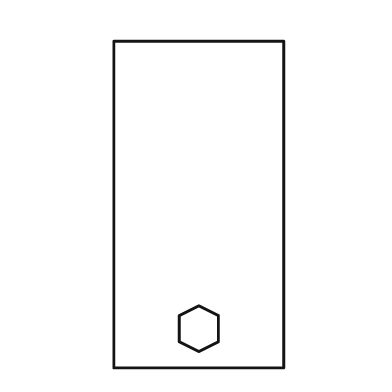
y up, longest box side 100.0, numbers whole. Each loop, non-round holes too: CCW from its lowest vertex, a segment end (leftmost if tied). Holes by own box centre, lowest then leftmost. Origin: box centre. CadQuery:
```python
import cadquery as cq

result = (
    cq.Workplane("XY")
    .moveTo(-26.0, -50.0)
    .lineTo(26.0, -50.0)
    .lineTo(26.0, 50.0)
    .lineTo(-26.0, 50.0)
    .close()
    .moveTo(0.0, -45.0)
    .lineTo(6.0, -42.0)
    .lineTo(6.0, -34.0)
    .lineTo(0.0, -31.0)
    .lineTo(-6.0, -34.0)
    .lineTo(-6.0, -42.0)
    .close()
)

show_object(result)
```